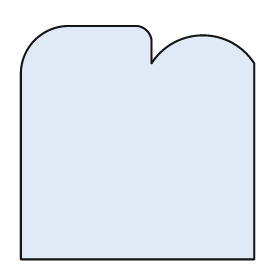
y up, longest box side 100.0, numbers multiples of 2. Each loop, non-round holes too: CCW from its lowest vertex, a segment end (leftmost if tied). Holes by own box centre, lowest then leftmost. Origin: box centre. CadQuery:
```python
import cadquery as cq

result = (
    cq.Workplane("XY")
    .moveTo(-50.0, -50.0)
    .lineTo(50.0, -50.0)
    .lineTo(50.0, 34.0)
    .threePointArc((28.0, 46.0), (6.0, 34.0))
    .lineTo(6.0, 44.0)
    .threePointArc((4.0, 48.0), (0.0, 50.0))
    .lineTo(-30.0, 50.0)
    .threePointArc((-44.0, 44.0), (-50.0, 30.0))
    .close()
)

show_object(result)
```